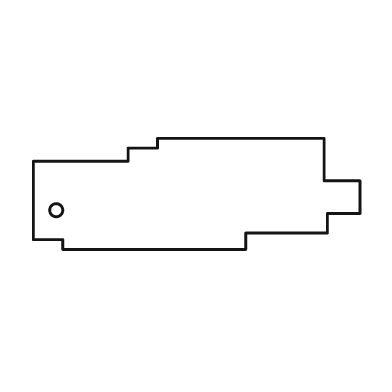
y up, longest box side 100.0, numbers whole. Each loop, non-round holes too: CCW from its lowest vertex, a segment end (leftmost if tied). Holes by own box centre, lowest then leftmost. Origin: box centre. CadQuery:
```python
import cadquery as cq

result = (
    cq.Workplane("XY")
    .moveTo(-41.0, -17.0)
    .lineTo(15.0, -17.0)
    .lineTo(15.0, -12.0)
    .lineTo(40.0, -12.0)
    .lineTo(40.0, -6.0)
    .lineTo(50.0, -6.0)
    .lineTo(50.0, 4.0)
    .lineTo(39.0, 4.0)
    .lineTo(39.0, 17.0)
    .lineTo(-12.0, 17.0)
    .lineTo(-12.0, 14.0)
    .lineTo(-21.0, 14.0)
    .lineTo(-21.0, 10.0)
    .lineTo(-50.0, 10.0)
    .lineTo(-50.0, -14.0)
    .lineTo(-41.0, -14.0)
    .close()
    .moveTo(-43.0, -5.0)
    .circle(2.0)
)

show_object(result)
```